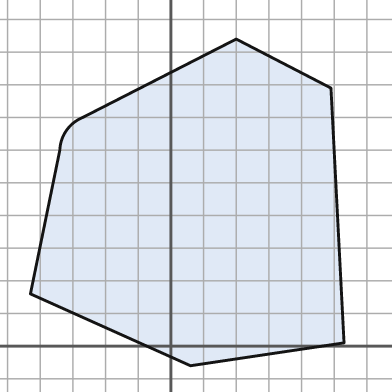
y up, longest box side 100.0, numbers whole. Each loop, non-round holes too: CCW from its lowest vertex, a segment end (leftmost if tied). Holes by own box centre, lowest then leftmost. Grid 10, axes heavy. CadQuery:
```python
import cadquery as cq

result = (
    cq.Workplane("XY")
    .moveTo(6.0, -6.0)
    .lineTo(53.0, 1.0)
    .lineTo(49.0, 79.0)
    .lineTo(20.0, 94.0)
    .lineTo(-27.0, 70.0)
    .threePointArc((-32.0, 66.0), (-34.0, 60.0))
    .lineTo(-43.0, 16.0)
    .close()
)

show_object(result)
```